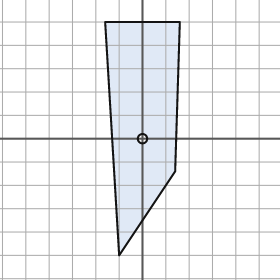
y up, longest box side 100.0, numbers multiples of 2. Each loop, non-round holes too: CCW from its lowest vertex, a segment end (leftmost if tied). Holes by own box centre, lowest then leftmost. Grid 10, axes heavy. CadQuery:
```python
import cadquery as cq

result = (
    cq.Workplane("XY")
    .moveTo(-10.0, -50.0)
    .lineTo(14.0, -14.0)
    .lineTo(16.0, 50.0)
    .lineTo(-16.0, 50.0)
    .close()
    .moveTo(0.0, 0.0)
    .circle(2.0)
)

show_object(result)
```